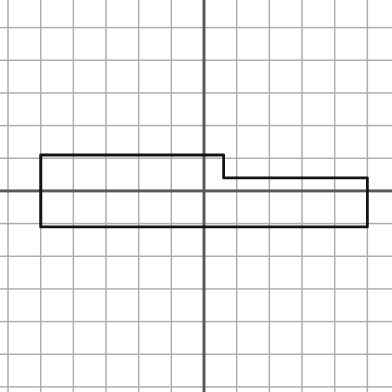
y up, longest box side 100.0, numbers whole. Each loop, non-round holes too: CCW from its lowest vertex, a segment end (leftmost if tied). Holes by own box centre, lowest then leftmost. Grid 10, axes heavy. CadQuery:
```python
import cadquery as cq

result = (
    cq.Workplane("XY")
    .moveTo(-50.0, -11.0)
    .lineTo(50.0, -11.0)
    .lineTo(50.0, 4.0)
    .lineTo(6.0, 4.0)
    .lineTo(6.0, 11.0)
    .lineTo(-50.0, 11.0)
    .close()
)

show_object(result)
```